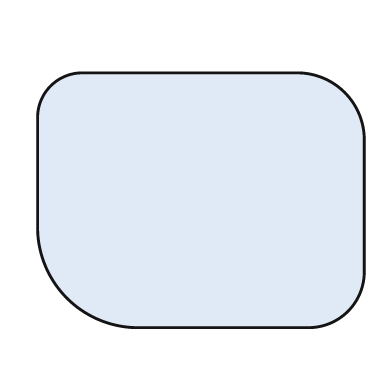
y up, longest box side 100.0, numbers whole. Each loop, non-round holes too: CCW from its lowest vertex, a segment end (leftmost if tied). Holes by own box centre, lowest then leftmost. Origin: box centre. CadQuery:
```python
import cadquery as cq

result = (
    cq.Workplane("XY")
    .moveTo(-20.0, -39.0)
    .lineTo(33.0, -39.0)
    .threePointArc((45.0, -34.0), (50.0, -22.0))
    .lineTo(50.0, 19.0)
    .threePointArc((44.0, 33.0), (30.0, 39.0))
    .lineTo(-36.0, 39.0)
    .threePointArc((-46.0, 35.0), (-50.0, 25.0))
    .lineTo(-50.0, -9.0)
    .threePointArc((-41.0, -30.0), (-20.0, -39.0))
    .close()
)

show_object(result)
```